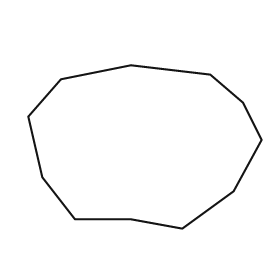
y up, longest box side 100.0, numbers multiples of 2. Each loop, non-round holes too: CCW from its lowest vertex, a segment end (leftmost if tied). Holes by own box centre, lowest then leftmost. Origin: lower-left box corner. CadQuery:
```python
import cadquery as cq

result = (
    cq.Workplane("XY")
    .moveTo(66.0, 0.0)
    .lineTo(88.0, 16.0)
    .lineTo(100.0, 38.0)
    .lineTo(92.0, 54.0)
    .lineTo(78.0, 66.0)
    .lineTo(44.0, 70.0)
    .lineTo(14.0, 64.0)
    .lineTo(0.0, 48.0)
    .lineTo(6.0, 22.0)
    .lineTo(20.0, 4.0)
    .lineTo(44.0, 4.0)
    .close()
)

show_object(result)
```